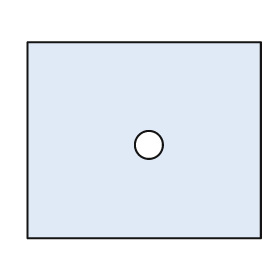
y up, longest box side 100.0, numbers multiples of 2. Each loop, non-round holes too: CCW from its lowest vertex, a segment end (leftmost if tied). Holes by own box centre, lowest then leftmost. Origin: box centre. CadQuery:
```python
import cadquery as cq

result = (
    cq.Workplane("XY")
    .moveTo(-50.0, -42.0)
    .lineTo(50.0, -42.0)
    .lineTo(50.0, 42.0)
    .lineTo(-50.0, 42.0)
    .close()
    .moveTo(2.0, -2.0)
    .circle(6.0)
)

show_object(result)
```